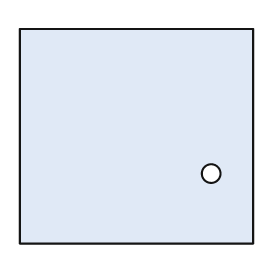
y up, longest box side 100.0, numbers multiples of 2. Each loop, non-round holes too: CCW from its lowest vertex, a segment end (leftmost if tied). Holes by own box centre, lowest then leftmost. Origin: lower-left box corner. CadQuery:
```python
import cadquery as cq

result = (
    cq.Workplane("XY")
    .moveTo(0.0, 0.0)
    .lineTo(100.0, 0.0)
    .lineTo(100.0, 92.0)
    .lineTo(0.0, 92.0)
    .close()
    .moveTo(82.0, 30.0)
    .circle(4.0)
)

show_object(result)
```